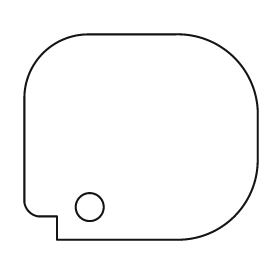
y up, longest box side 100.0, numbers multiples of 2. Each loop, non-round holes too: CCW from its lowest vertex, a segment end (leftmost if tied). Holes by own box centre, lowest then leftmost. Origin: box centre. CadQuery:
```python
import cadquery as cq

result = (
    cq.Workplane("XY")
    .moveTo(-36.0, -44.0)
    .lineTo(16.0, -44.0)
    .threePointArc((40.0, -34.0), (50.0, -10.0))
    .lineTo(50.0, 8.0)
    .threePointArc((40.0, 34.0), (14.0, 44.0))
    .lineTo(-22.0, 44.0)
    .threePointArc((-42.0, 36.0), (-50.0, 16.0))
    .lineTo(-50.0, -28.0)
    .threePointArc((-48.0, -32.0), (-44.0, -34.0))
    .lineTo(-36.0, -34.0)
    .close()
    .moveTo(-22.0, -30.0)
    .circle(6.0)
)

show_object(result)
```